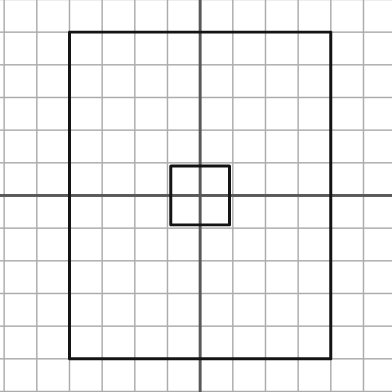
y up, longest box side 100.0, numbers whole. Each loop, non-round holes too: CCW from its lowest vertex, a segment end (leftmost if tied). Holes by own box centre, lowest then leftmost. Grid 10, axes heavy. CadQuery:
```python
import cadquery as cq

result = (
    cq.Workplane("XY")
    .moveTo(-40.0, -50.0)
    .lineTo(40.0, -50.0)
    .lineTo(40.0, 50.0)
    .lineTo(-40.0, 50.0)
    .close()
    .moveTo(-9.0, -9.0)
    .lineTo(9.0, -9.0)
    .lineTo(9.0, 9.0)
    .lineTo(-9.0, 9.0)
    .close()
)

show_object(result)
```